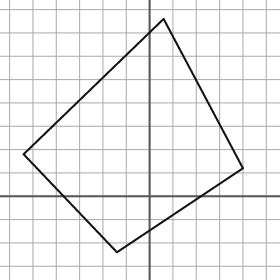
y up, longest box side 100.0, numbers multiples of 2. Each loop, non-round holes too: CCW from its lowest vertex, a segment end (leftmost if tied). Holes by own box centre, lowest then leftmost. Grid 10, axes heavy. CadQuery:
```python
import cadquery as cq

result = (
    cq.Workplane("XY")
    .moveTo(-14.0, -24.0)
    .lineTo(40.0, 12.0)
    .lineTo(6.0, 76.0)
    .lineTo(-54.0, 18.0)
    .close()
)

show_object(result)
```